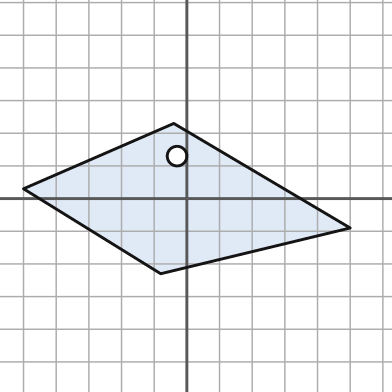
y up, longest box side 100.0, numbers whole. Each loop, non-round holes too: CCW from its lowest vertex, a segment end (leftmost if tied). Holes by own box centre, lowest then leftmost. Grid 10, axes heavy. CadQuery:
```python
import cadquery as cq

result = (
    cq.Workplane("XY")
    .moveTo(-8.0, -23.0)
    .lineTo(50.0, -9.0)
    .lineTo(-4.0, 23.0)
    .lineTo(-50.0, 3.0)
    .close()
    .moveTo(-3.0, 13.0)
    .circle(3.0)
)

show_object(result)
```